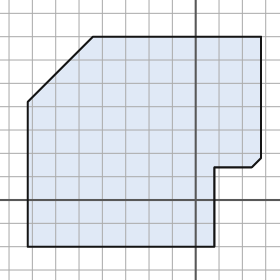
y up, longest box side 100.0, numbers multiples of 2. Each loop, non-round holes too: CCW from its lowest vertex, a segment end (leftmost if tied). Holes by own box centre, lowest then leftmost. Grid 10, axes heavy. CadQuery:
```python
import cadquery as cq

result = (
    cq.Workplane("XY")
    .moveTo(-72.0, -20.0)
    .lineTo(8.0, -20.0)
    .lineTo(8.0, 14.0)
    .lineTo(24.0, 14.0)
    .lineTo(28.0, 18.0)
    .lineTo(28.0, 70.0)
    .lineTo(-44.0, 70.0)
    .lineTo(-72.0, 42.0)
    .close()
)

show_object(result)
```